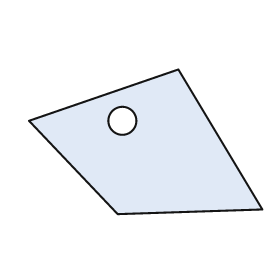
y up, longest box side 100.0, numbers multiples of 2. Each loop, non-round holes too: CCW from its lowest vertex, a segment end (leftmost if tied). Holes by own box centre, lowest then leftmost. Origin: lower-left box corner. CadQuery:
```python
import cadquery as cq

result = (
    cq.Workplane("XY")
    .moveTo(38.0, 0.0)
    .lineTo(100.0, 2.0)
    .lineTo(64.0, 62.0)
    .lineTo(0.0, 40.0)
    .close()
    .moveTo(40.0, 40.0)
    .circle(6.0)
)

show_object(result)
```